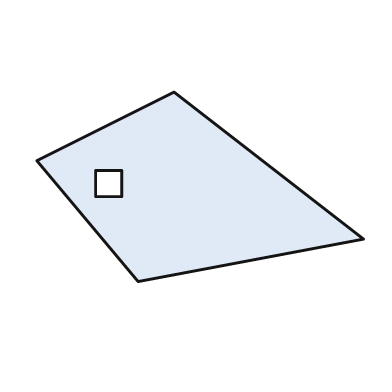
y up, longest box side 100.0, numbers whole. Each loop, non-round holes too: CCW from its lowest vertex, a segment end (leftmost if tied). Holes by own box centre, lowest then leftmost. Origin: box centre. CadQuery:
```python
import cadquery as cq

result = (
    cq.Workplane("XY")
    .moveTo(-19.0, -29.0)
    .lineTo(50.0, -16.0)
    .lineTo(-8.0, 29.0)
    .lineTo(-50.0, 8.0)
    .close()
    .moveTo(-32.0, -3.0)
    .lineTo(-24.0, -3.0)
    .lineTo(-24.0, 5.0)
    .lineTo(-32.0, 5.0)
    .close()
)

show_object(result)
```